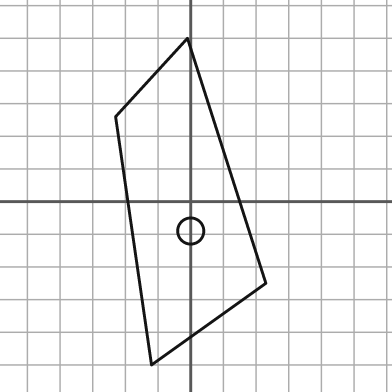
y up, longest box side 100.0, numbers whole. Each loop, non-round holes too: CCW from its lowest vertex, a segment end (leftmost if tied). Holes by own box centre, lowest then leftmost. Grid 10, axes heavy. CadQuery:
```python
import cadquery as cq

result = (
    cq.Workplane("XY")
    .moveTo(-12.0, -50.0)
    .lineTo(23.0, -25.0)
    .lineTo(-1.0, 50.0)
    .lineTo(-23.0, 26.0)
    .close()
    .moveTo(0.0, -9.0)
    .circle(4.0)
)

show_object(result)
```